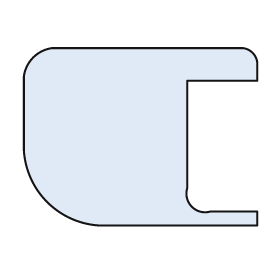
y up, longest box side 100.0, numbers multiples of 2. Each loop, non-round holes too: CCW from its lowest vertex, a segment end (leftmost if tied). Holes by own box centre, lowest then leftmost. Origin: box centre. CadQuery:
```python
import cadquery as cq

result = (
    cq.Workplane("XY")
    .moveTo(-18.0, -38.0)
    .lineTo(50.0, -38.0)
    .lineTo(50.0, -32.0)
    .lineTo(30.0, -32.0)
    .threePointArc((22.0, -30.0), (20.0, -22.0))
    .lineTo(20.0, 24.0)
    .lineTo(50.0, 24.0)
    .lineTo(50.0, 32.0)
    .threePointArc((48.0, 36.0), (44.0, 38.0))
    .lineTo(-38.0, 38.0)
    .threePointArc((-46.0, 34.0), (-50.0, 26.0))
    .lineTo(-50.0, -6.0)
    .threePointArc((-40.0, -28.0), (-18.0, -38.0))
    .close()
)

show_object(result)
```